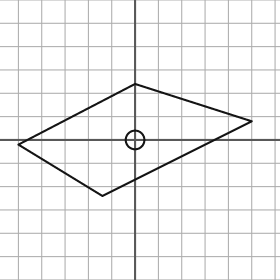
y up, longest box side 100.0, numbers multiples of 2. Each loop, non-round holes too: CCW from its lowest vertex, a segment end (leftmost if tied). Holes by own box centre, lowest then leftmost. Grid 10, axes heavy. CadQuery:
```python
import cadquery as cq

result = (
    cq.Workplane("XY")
    .moveTo(-14.0, -24.0)
    .lineTo(50.0, 8.0)
    .lineTo(0.0, 24.0)
    .lineTo(-50.0, -2.0)
    .close()
    .moveTo(0.0, 0.0)
    .circle(4.0)
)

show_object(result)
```